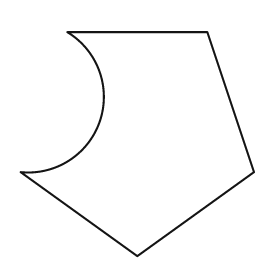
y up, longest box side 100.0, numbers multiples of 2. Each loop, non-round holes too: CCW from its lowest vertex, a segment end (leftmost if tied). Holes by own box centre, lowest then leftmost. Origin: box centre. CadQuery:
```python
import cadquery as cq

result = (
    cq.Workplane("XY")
    .moveTo(0.0, -48.0)
    .lineTo(50.0, -12.0)
    .lineTo(30.0, 48.0)
    .lineTo(-30.0, 48.0)
    .threePointArc((-16.0, 10.0), (-50.0, -12.0))
    .close()
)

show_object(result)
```